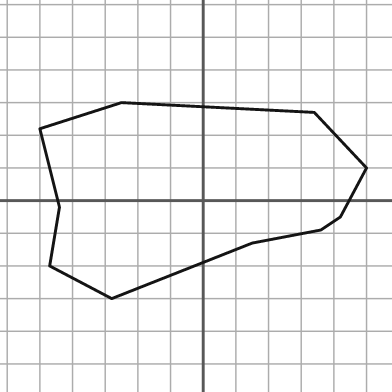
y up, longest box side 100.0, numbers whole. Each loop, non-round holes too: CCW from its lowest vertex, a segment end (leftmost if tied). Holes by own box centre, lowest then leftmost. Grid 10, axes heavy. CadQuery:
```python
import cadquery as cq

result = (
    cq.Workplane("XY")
    .moveTo(-28.0, -30.0)
    .lineTo(15.0, -13.0)
    .lineTo(36.0, -9.0)
    .lineTo(42.0, -5.0)
    .lineTo(50.0, 10.0)
    .lineTo(34.0, 27.0)
    .lineTo(-25.0, 30.0)
    .lineTo(-50.0, 22.0)
    .lineTo(-44.0, -2.0)
    .lineTo(-47.0, -20.0)
    .close()
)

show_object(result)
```